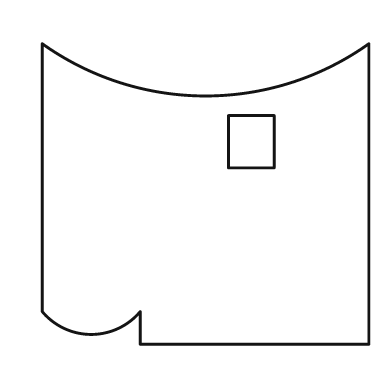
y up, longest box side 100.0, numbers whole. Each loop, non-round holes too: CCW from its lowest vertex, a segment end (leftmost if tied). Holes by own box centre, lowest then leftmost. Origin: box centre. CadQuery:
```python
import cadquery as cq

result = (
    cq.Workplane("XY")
    .moveTo(-20.0, -46.0)
    .lineTo(50.0, -46.0)
    .lineTo(50.0, 46.0)
    .threePointArc((0.0, 30.0), (-50.0, 46.0))
    .lineTo(-50.0, -36.0)
    .threePointArc((-35.0, -43.0), (-20.0, -36.0))
    .close()
    .moveTo(7.0, 8.0)
    .lineTo(21.0, 8.0)
    .lineTo(21.0, 24.0)
    .lineTo(7.0, 24.0)
    .close()
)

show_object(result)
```